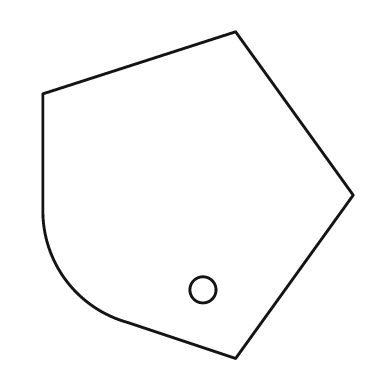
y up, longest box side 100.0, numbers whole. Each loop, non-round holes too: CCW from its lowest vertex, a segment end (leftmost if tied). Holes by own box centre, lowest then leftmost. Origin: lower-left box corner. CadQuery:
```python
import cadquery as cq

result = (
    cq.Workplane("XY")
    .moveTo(59.0, 0.0)
    .lineTo(95.0, 50.0)
    .lineTo(59.0, 100.0)
    .lineTo(0.0, 81.0)
    .lineTo(0.0, 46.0)
    .threePointArc((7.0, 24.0), (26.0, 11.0))
    .close()
    .moveTo(49.0, 21.0)
    .circle(4.0)
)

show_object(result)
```